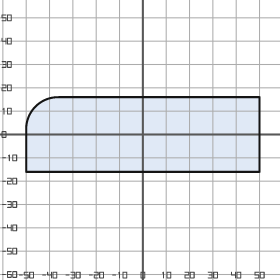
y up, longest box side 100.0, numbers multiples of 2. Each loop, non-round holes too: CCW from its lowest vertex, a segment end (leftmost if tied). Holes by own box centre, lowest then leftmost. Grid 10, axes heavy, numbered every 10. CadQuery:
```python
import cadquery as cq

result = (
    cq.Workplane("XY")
    .moveTo(-50.0, -16.0)
    .lineTo(50.0, -16.0)
    .lineTo(50.0, 16.0)
    .lineTo(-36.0, 16.0)
    .threePointArc((-46.0, 12.0), (-50.0, 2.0))
    .close()
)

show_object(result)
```